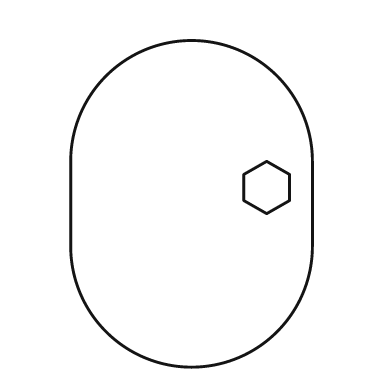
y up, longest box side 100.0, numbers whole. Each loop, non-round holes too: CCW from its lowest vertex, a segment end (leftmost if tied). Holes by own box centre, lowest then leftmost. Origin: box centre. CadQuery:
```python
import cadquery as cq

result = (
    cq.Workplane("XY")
    .moveTo(-37.0, -13.0)
    .threePointArc((0.0, -50.0), (37.0, -13.0))
    .lineTo(37.0, 13.0)
    .threePointArc((0.0, 50.0), (-37.0, 13.0))
    .close()
    .moveTo(23.0, -3.0)
    .lineTo(30.0, 1.0)
    .lineTo(30.0, 9.0)
    .lineTo(23.0, 13.0)
    .lineTo(16.0, 9.0)
    .lineTo(16.0, 1.0)
    .close()
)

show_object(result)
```